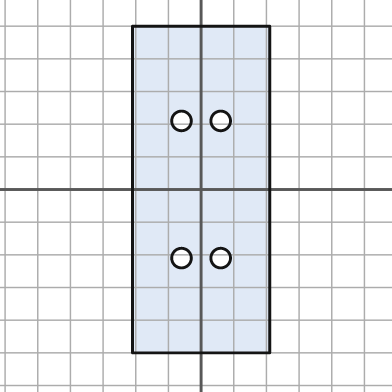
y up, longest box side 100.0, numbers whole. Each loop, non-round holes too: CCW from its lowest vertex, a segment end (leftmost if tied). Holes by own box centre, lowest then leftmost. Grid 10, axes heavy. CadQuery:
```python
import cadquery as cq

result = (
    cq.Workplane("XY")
    .moveTo(-21.0, -50.0)
    .lineTo(21.0, -50.0)
    .lineTo(21.0, 50.0)
    .lineTo(-21.0, 50.0)
    .close()
    .moveTo(-6.0, -21.0)
    .circle(3.0)
    .moveTo(6.0, -21.0)
    .circle(3.0)
    .moveTo(-6.0, 21.0)
    .circle(3.0)
    .moveTo(6.0, 21.0)
    .circle(3.0)
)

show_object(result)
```